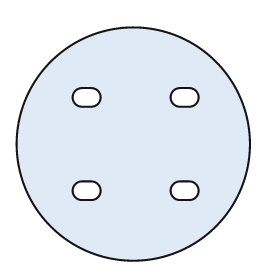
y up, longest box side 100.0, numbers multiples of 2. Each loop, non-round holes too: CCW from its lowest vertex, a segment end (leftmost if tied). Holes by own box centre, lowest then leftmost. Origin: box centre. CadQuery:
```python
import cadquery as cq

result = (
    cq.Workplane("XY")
    .moveTo(0.0, 0.0)
    .circle(50.0)
    .moveTo(-22.0, -24.0)
    .lineTo(-18.0, -24.0)
    .threePointArc((-14.0, -20.0), (-18.0, -16.0))
    .lineTo(-22.0, -16.0)
    .threePointArc((-26.0, -20.0), (-22.0, -24.0))
    .close()
    .moveTo(20.0, -24.0)
    .lineTo(24.0, -24.0)
    .threePointArc((28.0, -20.0), (24.0, -16.0))
    .lineTo(20.0, -16.0)
    .threePointArc((16.0, -20.0), (20.0, -24.0))
    .close()
    .moveTo(-22.0, 16.0)
    .lineTo(-18.0, 16.0)
    .threePointArc((-14.0, 20.0), (-18.0, 24.0))
    .lineTo(-22.0, 24.0)
    .threePointArc((-26.0, 20.0), (-22.0, 16.0))
    .close()
    .moveTo(20.0, 16.0)
    .lineTo(24.0, 16.0)
    .threePointArc((28.0, 20.0), (24.0, 24.0))
    .lineTo(20.0, 24.0)
    .threePointArc((16.0, 20.0), (20.0, 16.0))
    .close()
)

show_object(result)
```